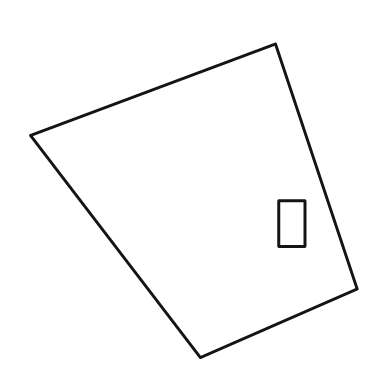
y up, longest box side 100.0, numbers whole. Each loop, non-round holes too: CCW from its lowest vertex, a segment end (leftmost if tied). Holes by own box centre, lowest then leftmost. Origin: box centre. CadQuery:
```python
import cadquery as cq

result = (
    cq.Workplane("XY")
    .moveTo(2.0, -48.0)
    .lineTo(50.0, -27.0)
    .lineTo(25.0, 48.0)
    .lineTo(-50.0, 20.0)
    .close()
    .moveTo(26.0, -14.0)
    .lineTo(34.0, -14.0)
    .lineTo(34.0, 0.0)
    .lineTo(26.0, 0.0)
    .close()
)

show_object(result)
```